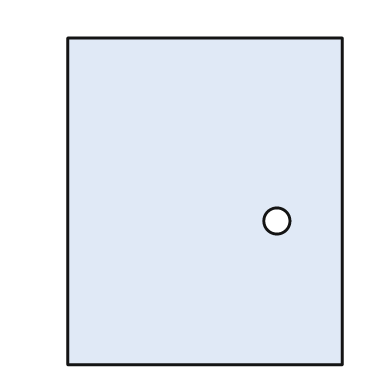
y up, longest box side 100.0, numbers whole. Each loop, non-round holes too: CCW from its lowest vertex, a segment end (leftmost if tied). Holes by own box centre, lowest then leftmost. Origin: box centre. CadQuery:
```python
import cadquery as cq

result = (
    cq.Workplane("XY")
    .moveTo(-42.0, -50.0)
    .lineTo(42.0, -50.0)
    .lineTo(42.0, 50.0)
    .lineTo(-42.0, 50.0)
    .close()
    .moveTo(22.0, -6.0)
    .circle(4.0)
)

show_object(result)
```